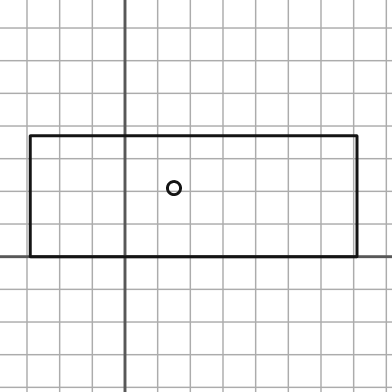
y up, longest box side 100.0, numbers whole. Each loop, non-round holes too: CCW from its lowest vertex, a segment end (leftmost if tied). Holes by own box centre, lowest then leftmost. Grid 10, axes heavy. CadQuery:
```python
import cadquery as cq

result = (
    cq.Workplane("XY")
    .moveTo(-29.0, 0.0)
    .lineTo(71.0, 0.0)
    .lineTo(71.0, 37.0)
    .lineTo(-29.0, 37.0)
    .close()
    .moveTo(15.0, 21.0)
    .circle(2.0)
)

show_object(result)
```